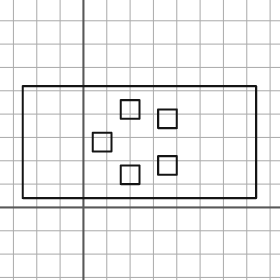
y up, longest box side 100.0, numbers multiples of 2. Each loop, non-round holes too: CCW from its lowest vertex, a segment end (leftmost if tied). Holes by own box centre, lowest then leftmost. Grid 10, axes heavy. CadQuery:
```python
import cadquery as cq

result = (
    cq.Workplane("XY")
    .moveTo(-26.0, 4.0)
    .lineTo(74.0, 4.0)
    .lineTo(74.0, 52.0)
    .lineTo(-26.0, 52.0)
    .close()
    .moveTo(16.0, 10.0)
    .lineTo(24.0, 10.0)
    .lineTo(24.0, 18.0)
    .lineTo(16.0, 18.0)
    .close()
    .moveTo(32.0, 14.0)
    .lineTo(40.0, 14.0)
    .lineTo(40.0, 22.0)
    .lineTo(32.0, 22.0)
    .close()
    .moveTo(4.0, 24.0)
    .lineTo(12.0, 24.0)
    .lineTo(12.0, 32.0)
    .lineTo(4.0, 32.0)
    .close()
    .moveTo(32.0, 34.0)
    .lineTo(40.0, 34.0)
    .lineTo(40.0, 42.0)
    .lineTo(32.0, 42.0)
    .close()
    .moveTo(16.0, 38.0)
    .lineTo(24.0, 38.0)
    .lineTo(24.0, 46.0)
    .lineTo(16.0, 46.0)
    .close()
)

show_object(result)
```